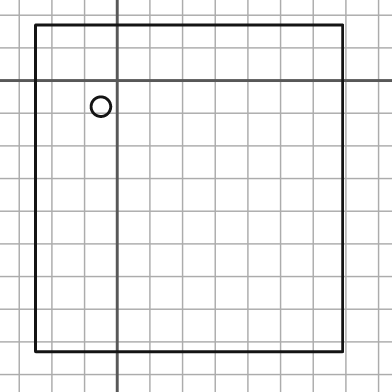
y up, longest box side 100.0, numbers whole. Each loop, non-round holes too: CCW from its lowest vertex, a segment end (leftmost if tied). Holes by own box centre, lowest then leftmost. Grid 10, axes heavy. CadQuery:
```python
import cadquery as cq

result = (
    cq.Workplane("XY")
    .moveTo(-25.0, -83.0)
    .lineTo(69.0, -83.0)
    .lineTo(69.0, 17.0)
    .lineTo(-25.0, 17.0)
    .close()
    .moveTo(-5.0, -8.0)
    .circle(3.0)
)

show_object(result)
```